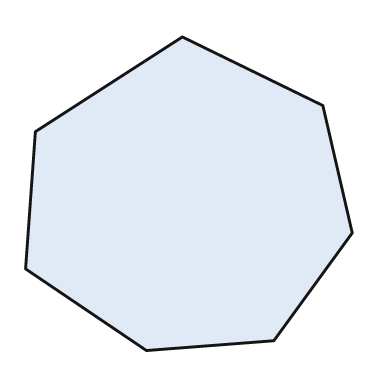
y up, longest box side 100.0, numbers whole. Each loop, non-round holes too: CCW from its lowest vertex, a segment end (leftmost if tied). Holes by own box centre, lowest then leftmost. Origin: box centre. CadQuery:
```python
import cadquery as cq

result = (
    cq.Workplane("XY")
    .moveTo(-13.0, -48.0)
    .lineTo(26.0, -45.0)
    .lineTo(50.0, -12.0)
    .lineTo(41.0, 27.0)
    .lineTo(-2.0, 48.0)
    .lineTo(-47.0, 19.0)
    .lineTo(-50.0, -23.0)
    .close()
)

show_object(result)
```